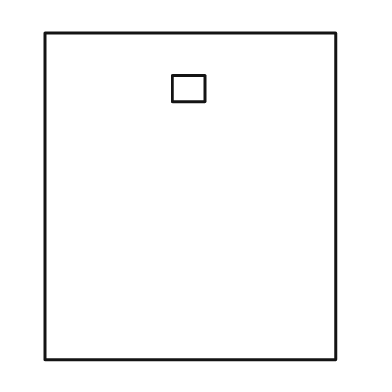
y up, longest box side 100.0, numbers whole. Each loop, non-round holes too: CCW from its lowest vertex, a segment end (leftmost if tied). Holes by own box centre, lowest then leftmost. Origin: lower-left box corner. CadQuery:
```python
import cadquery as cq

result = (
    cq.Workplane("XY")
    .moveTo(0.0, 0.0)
    .lineTo(89.0, 0.0)
    .lineTo(89.0, 100.0)
    .lineTo(0.0, 100.0)
    .close()
    .moveTo(39.0, 79.0)
    .lineTo(49.0, 79.0)
    .lineTo(49.0, 87.0)
    .lineTo(39.0, 87.0)
    .close()
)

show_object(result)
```